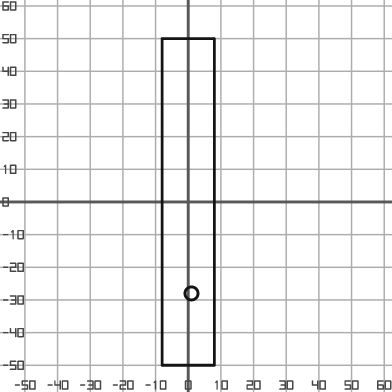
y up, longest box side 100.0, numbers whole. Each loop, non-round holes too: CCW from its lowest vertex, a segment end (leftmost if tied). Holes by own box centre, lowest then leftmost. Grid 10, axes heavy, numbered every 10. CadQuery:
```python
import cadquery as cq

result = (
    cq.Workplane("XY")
    .moveTo(-8.0, -50.0)
    .lineTo(8.0, -50.0)
    .lineTo(8.0, 50.0)
    .lineTo(-8.0, 50.0)
    .close()
    .moveTo(1.0, -28.0)
    .circle(2.0)
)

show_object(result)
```